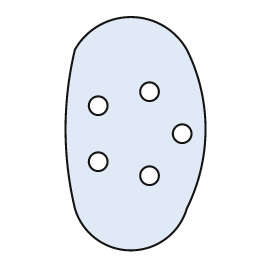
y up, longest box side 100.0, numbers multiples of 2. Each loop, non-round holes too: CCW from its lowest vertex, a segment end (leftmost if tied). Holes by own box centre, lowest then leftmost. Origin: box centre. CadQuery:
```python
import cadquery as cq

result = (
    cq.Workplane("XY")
    .moveTo(-26.0, -32.0)
    .threePointArc((-2.0, -50.0), (22.0, -32.0))
    .threePointArc((30.0, 2.0), (22.0, 36.0))
    .threePointArc((-2.0, 50.0), (-26.0, 36.0))
    .threePointArc((-30.0, 2.0), (-26.0, -32.0))
    .close()
    .moveTo(6.0, -18.0)
    .circle(4.0)
    .moveTo(-16.0, -12.0)
    .circle(4.0)
    .moveTo(20.0, 0.0)
    .circle(4.0)
    .moveTo(-16.0, 12.0)
    .circle(4.0)
    .moveTo(6.0, 18.0)
    .circle(4.0)
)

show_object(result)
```